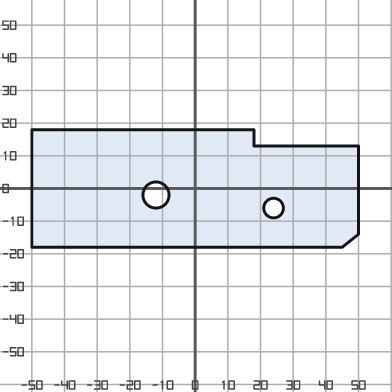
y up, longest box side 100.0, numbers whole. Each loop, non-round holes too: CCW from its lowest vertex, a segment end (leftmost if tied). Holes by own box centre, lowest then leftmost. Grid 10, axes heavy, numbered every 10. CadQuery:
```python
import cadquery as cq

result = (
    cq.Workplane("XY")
    .moveTo(-50.0, -18.0)
    .lineTo(45.0, -18.0)
    .lineTo(50.0, -14.0)
    .lineTo(50.0, 13.0)
    .lineTo(18.0, 13.0)
    .lineTo(18.0, 18.0)
    .lineTo(-50.0, 18.0)
    .close()
    .moveTo(24.0, -6.0)
    .circle(3.0)
    .moveTo(-12.0, -2.0)
    .circle(4.0)
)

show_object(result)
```